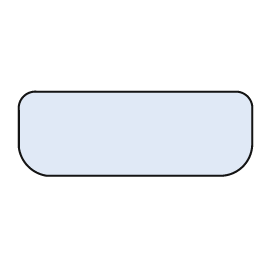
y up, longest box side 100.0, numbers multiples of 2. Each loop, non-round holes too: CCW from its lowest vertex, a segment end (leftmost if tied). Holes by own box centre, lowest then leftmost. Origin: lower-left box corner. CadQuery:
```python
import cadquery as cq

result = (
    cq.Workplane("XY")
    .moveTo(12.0, 0.0)
    .lineTo(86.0, 0.0)
    .threePointArc((96.0, 4.0), (100.0, 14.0))
    .lineTo(100.0, 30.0)
    .threePointArc((98.0, 34.0), (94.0, 36.0))
    .lineTo(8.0, 36.0)
    .threePointArc((2.0, 34.0), (0.0, 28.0))
    .lineTo(0.0, 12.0)
    .threePointArc((4.0, 4.0), (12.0, 0.0))
    .close()
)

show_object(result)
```